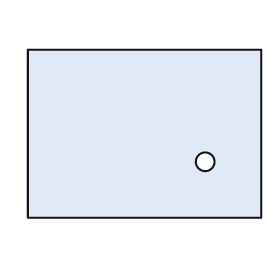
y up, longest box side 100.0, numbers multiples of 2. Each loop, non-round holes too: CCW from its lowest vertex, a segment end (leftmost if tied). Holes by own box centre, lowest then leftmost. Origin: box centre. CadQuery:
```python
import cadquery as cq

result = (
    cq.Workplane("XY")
    .moveTo(-50.0, -36.0)
    .lineTo(50.0, -36.0)
    .lineTo(50.0, 36.0)
    .lineTo(-50.0, 36.0)
    .close()
    .moveTo(26.0, -12.0)
    .circle(4.0)
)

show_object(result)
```